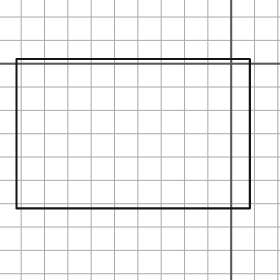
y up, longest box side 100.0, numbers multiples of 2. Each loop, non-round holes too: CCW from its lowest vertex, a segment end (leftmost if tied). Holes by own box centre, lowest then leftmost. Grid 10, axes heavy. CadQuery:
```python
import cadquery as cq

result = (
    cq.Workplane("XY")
    .moveTo(-92.0, -62.0)
    .lineTo(8.0, -62.0)
    .lineTo(8.0, 2.0)
    .lineTo(-92.0, 2.0)
    .close()
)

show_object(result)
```